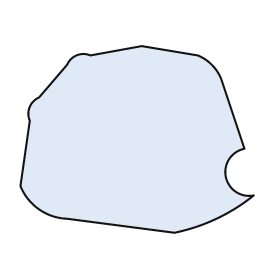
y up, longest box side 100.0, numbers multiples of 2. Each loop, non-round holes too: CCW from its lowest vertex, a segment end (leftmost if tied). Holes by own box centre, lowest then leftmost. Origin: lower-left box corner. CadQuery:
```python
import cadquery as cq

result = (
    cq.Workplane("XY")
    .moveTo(66.0, 0.0)
    .threePointArc((84.0, 6.0), (100.0, 16.0))
    .threePointArc((88.0, 24.0), (96.0, 36.0))
    .lineTo(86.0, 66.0)
    .threePointArc((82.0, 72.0), (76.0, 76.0))
    .lineTo(52.0, 80.0)
    .lineTo(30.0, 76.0)
    .threePointArc((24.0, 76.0), (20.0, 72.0))
    .lineTo(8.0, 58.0)
    .threePointArc((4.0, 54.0), (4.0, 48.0))
    .lineTo(0.0, 20.0)
    .threePointArc((8.0, 10.0), (20.0, 6.0))
    .close()
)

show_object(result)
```